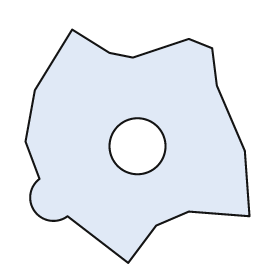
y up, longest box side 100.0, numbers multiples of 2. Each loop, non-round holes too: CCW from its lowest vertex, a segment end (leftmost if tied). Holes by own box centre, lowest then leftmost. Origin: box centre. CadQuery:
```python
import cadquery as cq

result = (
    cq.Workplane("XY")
    .moveTo(-4.0, -50.0)
    .lineTo(8.0, -34.0)
    .lineTo(22.0, -28.0)
    .lineTo(48.0, -30.0)
    .lineTo(46.0, -2.0)
    .lineTo(34.0, 26.0)
    .lineTo(32.0, 42.0)
    .lineTo(22.0, 46.0)
    .lineTo(-2.0, 38.0)
    .lineTo(-12.0, 40.0)
    .lineTo(-28.0, 50.0)
    .lineTo(-44.0, 24.0)
    .lineTo(-48.0, 2.0)
    .lineTo(-42.0, -14.0)
    .threePointArc((-44.0, -28.0), (-30.0, -30.0))
    .close()
    .moveTo(0.0, 0.0)
    .circle(12.0)
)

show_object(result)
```